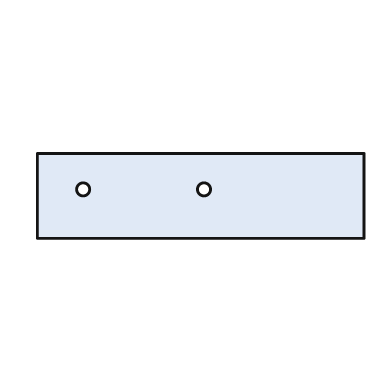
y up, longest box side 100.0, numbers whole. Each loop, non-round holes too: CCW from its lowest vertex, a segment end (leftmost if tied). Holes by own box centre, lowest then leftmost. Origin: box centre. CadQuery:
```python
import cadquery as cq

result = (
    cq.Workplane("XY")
    .moveTo(-50.0, -13.0)
    .lineTo(50.0, -13.0)
    .lineTo(50.0, 13.0)
    .lineTo(-50.0, 13.0)
    .close()
    .moveTo(-36.0, 2.0)
    .circle(2.0)
    .moveTo(1.0, 2.0)
    .circle(2.0)
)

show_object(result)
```